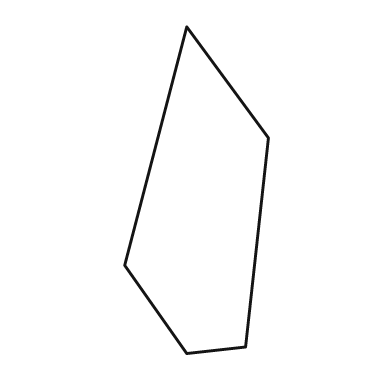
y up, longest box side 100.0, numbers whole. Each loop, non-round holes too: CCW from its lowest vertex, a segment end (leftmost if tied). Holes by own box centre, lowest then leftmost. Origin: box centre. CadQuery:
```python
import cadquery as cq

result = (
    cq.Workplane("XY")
    .moveTo(-3.0, -50.0)
    .lineTo(15.0, -48.0)
    .lineTo(22.0, 16.0)
    .lineTo(-3.0, 50.0)
    .lineTo(-22.0, -23.0)
    .close()
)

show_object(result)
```